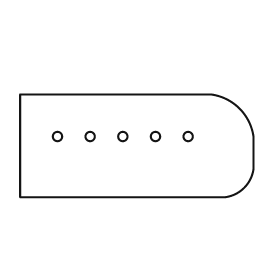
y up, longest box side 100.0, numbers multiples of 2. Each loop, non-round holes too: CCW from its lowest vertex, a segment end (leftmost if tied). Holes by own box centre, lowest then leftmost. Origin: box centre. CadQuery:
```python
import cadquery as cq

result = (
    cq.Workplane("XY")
    .moveTo(-50.0, -22.0)
    .lineTo(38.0, -22.0)
    .threePointArc((46.0, -18.0), (50.0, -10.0))
    .lineTo(50.0, 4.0)
    .threePointArc((44.0, 16.0), (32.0, 22.0))
    .lineTo(-50.0, 22.0)
    .close()
    .moveTo(-34.0, 4.0)
    .circle(2.0)
    .moveTo(-20.0, 4.0)
    .circle(2.0)
    .moveTo(-6.0, 4.0)
    .circle(2.0)
    .moveTo(8.0, 4.0)
    .circle(2.0)
    .moveTo(22.0, 4.0)
    .circle(2.0)
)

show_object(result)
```